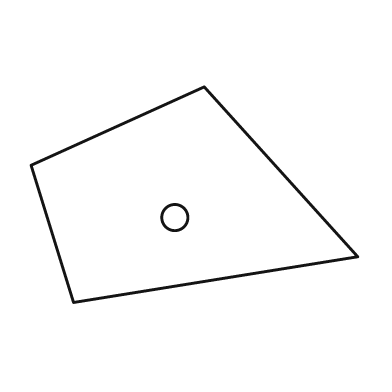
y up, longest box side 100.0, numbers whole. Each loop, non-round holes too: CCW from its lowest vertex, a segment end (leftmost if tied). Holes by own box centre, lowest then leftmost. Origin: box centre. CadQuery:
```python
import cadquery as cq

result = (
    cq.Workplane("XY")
    .moveTo(-37.0, -33.0)
    .lineTo(50.0, -19.0)
    .lineTo(3.0, 33.0)
    .lineTo(-50.0, 9.0)
    .close()
    .moveTo(-6.0, -7.0)
    .circle(4.0)
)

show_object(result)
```